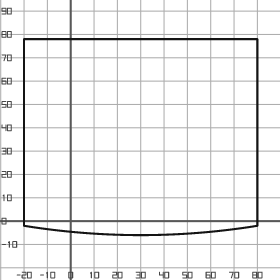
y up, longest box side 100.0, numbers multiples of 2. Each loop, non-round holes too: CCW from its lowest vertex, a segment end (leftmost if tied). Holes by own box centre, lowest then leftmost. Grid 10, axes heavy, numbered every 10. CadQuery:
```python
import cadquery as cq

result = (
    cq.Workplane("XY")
    .moveTo(-20.0, -2.0)
    .threePointArc((30.0, -6.0), (80.0, -2.0))
    .lineTo(80.0, 78.0)
    .lineTo(-20.0, 78.0)
    .close()
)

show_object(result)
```